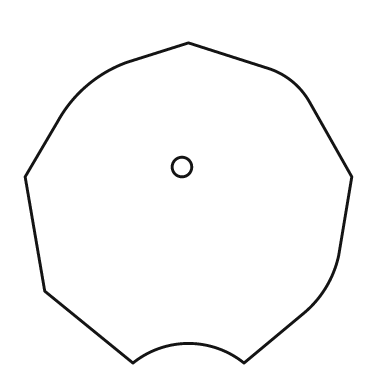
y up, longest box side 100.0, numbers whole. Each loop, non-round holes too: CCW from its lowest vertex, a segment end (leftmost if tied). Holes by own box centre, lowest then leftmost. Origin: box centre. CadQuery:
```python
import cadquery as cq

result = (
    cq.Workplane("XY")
    .moveTo(-17.0, -49.0)
    .threePointArc((0.0, -43.0), (17.0, -49.0))
    .lineTo(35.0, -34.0)
    .threePointArc((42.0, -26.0), (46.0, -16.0))
    .lineTo(50.0, 8.0)
    .lineTo(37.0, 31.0)
    .threePointArc((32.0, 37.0), (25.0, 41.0))
    .lineTo(0.0, 49.0)
    .lineTo(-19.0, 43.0)
    .threePointArc((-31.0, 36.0), (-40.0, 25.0))
    .lineTo(-50.0, 8.0)
    .lineTo(-44.0, -27.0)
    .close()
    .moveTo(-2.0, 11.0)
    .circle(3.0)
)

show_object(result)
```